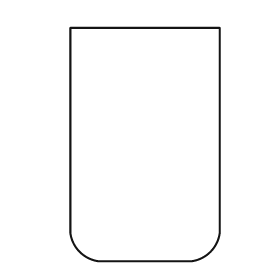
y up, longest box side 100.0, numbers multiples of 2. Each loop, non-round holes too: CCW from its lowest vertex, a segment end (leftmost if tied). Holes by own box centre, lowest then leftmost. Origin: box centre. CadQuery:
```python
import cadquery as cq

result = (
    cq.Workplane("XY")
    .moveTo(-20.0, -50.0)
    .lineTo(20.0, -50.0)
    .threePointArc((28.0, -46.0), (32.0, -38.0))
    .lineTo(32.0, 50.0)
    .lineTo(-32.0, 50.0)
    .lineTo(-32.0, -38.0)
    .threePointArc((-28.0, -46.0), (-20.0, -50.0))
    .close()
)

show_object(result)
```